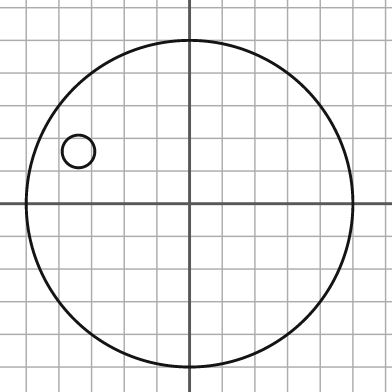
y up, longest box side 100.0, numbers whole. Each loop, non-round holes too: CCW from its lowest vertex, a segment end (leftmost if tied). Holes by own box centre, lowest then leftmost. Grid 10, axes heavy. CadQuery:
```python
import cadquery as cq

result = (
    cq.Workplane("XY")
    .moveTo(0.0, 0.0)
    .circle(50.0)
    .moveTo(-34.0, 16.0)
    .circle(5.0)
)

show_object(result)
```